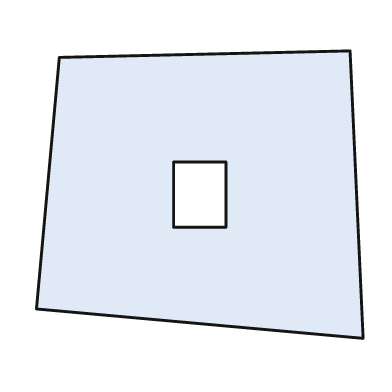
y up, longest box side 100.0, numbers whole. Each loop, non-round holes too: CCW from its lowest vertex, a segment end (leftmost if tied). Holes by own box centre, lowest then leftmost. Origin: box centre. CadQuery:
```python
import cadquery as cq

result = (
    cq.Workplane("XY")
    .moveTo(50.0, -44.0)
    .lineTo(46.0, 44.0)
    .lineTo(-43.0, 42.0)
    .lineTo(-50.0, -35.0)
    .close()
    .moveTo(-8.0, -10.0)
    .lineTo(8.0, -10.0)
    .lineTo(8.0, 10.0)
    .lineTo(-8.0, 10.0)
    .close()
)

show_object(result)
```